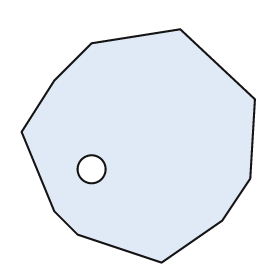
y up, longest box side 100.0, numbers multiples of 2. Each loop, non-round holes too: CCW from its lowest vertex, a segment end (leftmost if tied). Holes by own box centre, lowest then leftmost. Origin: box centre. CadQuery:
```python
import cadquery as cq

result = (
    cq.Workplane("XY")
    .moveTo(10.0, -50.0)
    .lineTo(36.0, -32.0)
    .lineTo(48.0, -14.0)
    .lineTo(50.0, 20.0)
    .lineTo(18.0, 50.0)
    .lineTo(-20.0, 44.0)
    .lineTo(-36.0, 28.0)
    .lineTo(-50.0, 6.0)
    .lineTo(-36.0, -28.0)
    .lineTo(-26.0, -38.0)
    .close()
    .moveTo(-20.0, -10.0)
    .circle(6.0)
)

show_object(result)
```